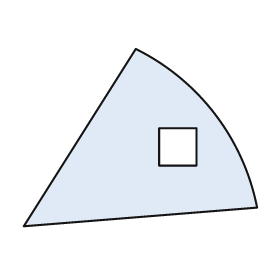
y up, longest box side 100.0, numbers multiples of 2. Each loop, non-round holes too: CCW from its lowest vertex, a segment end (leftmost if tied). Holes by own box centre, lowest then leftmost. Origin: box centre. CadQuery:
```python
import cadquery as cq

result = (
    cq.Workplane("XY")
    .moveTo(-50.0, -38.0)
    .lineTo(50.0, -30.0)
    .threePointArc((32.0, 10.0), (-2.0, 38.0))
    .close()
    .moveTo(8.0, -12.0)
    .lineTo(24.0, -12.0)
    .lineTo(24.0, 4.0)
    .lineTo(8.0, 4.0)
    .close()
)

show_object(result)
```